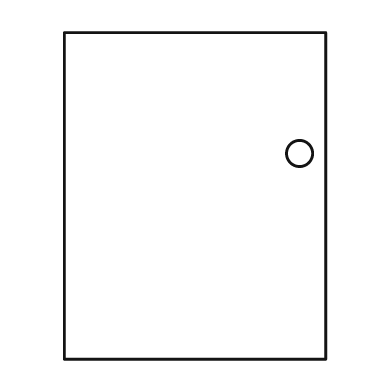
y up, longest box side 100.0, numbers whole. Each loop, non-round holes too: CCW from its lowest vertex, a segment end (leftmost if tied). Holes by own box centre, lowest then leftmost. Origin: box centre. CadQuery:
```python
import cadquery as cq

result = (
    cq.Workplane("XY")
    .moveTo(-40.0, -50.0)
    .lineTo(40.0, -50.0)
    .lineTo(40.0, 50.0)
    .lineTo(-40.0, 50.0)
    .close()
    .moveTo(32.0, 13.0)
    .circle(4.0)
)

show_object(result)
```